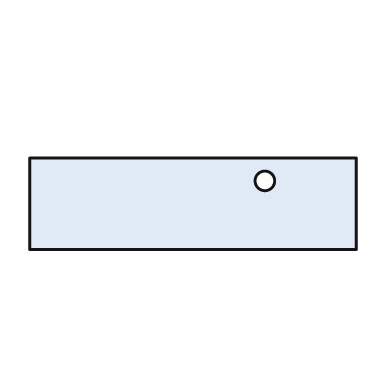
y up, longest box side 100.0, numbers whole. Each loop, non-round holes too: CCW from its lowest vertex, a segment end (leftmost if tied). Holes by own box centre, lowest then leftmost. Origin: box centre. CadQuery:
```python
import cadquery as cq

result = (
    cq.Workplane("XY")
    .moveTo(-50.0, -14.0)
    .lineTo(50.0, -14.0)
    .lineTo(50.0, 14.0)
    .lineTo(-50.0, 14.0)
    .close()
    .moveTo(22.0, 7.0)
    .circle(3.0)
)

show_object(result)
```